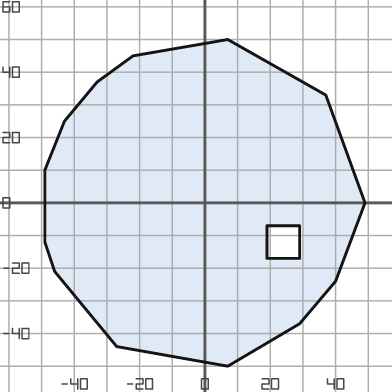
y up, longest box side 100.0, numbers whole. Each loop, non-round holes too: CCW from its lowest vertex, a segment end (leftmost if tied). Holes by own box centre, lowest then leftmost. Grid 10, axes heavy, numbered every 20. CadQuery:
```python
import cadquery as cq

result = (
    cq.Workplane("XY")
    .moveTo(7.0, -50.0)
    .lineTo(29.0, -37.0)
    .lineTo(40.0, -24.0)
    .lineTo(49.0, 0.0)
    .lineTo(37.0, 33.0)
    .lineTo(7.0, 50.0)
    .lineTo(-22.0, 45.0)
    .lineTo(-33.0, 37.0)
    .lineTo(-43.0, 25.0)
    .lineTo(-49.0, 10.0)
    .lineTo(-49.0, -12.0)
    .lineTo(-46.0, -21.0)
    .lineTo(-27.0, -44.0)
    .close()
    .moveTo(19.0, -17.0)
    .lineTo(29.0, -17.0)
    .lineTo(29.0, -7.0)
    .lineTo(19.0, -7.0)
    .close()
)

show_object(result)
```